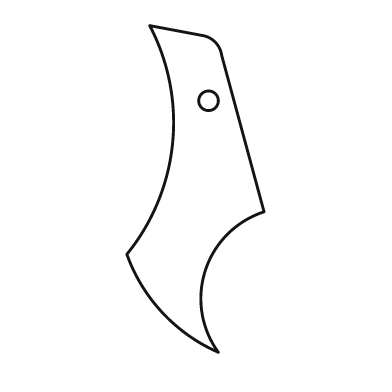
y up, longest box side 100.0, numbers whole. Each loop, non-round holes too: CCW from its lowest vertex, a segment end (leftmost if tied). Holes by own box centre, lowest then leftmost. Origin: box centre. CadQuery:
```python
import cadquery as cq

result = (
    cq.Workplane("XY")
    .moveTo(7.0, -50.0)
    .threePointArc((3.0, -25.0), (21.0, -7.0))
    .lineTo(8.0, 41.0)
    .threePointArc((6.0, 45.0), (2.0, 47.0))
    .lineTo(-14.0, 50.0)
    .threePointArc((-7.0, 14.0), (-21.0, -20.0))
    .threePointArc((-10.0, -38.0), (7.0, -50.0))
    .close()
    .moveTo(4.0, 27.0)
    .circle(3.0)
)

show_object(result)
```